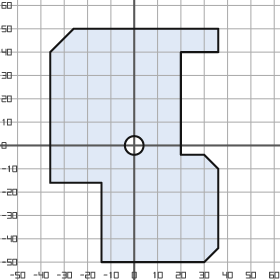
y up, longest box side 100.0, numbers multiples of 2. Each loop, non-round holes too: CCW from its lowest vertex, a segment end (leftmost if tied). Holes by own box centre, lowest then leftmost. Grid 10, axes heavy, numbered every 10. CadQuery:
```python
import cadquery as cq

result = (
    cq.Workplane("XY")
    .moveTo(-14.0, -50.0)
    .lineTo(30.0, -50.0)
    .lineTo(36.0, -44.0)
    .lineTo(36.0, -10.0)
    .lineTo(30.0, -4.0)
    .lineTo(20.0, -4.0)
    .lineTo(20.0, 40.0)
    .lineTo(36.0, 40.0)
    .lineTo(36.0, 50.0)
    .lineTo(-26.0, 50.0)
    .lineTo(-36.0, 40.0)
    .lineTo(-36.0, -16.0)
    .lineTo(-14.0, -16.0)
    .close()
    .moveTo(0.0, 0.0)
    .circle(4.0)
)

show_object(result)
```